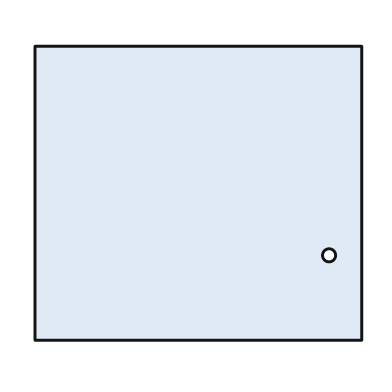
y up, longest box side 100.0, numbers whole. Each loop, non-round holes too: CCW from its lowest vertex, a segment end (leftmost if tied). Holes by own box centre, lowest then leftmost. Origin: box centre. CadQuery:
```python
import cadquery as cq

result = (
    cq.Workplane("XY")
    .moveTo(-50.0, -45.0)
    .lineTo(50.0, -45.0)
    .lineTo(50.0, 45.0)
    .lineTo(-50.0, 45.0)
    .close()
    .moveTo(40.0, -19.0)
    .circle(2.0)
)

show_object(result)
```